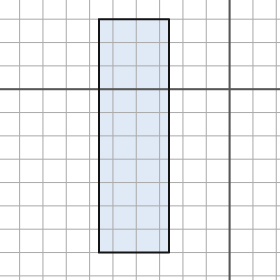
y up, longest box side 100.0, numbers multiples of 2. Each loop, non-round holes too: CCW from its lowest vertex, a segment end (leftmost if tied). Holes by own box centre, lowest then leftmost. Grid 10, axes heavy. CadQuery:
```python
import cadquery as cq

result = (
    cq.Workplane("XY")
    .moveTo(-56.0, -70.0)
    .lineTo(-26.0, -70.0)
    .lineTo(-26.0, 30.0)
    .lineTo(-56.0, 30.0)
    .close()
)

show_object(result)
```